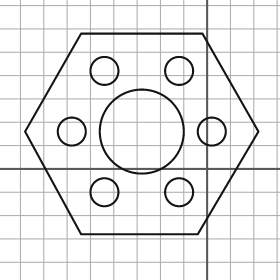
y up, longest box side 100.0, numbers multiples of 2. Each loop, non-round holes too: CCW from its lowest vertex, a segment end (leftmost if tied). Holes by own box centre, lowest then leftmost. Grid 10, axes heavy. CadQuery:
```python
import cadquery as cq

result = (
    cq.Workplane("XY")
    .moveTo(-54.0, -28.0)
    .lineTo(-4.0, -28.0)
    .lineTo(22.0, 16.0)
    .lineTo(-2.0, 58.0)
    .lineTo(-54.0, 58.0)
    .lineTo(-78.0, 16.0)
    .close()
    .moveTo(-44.0, -10.0)
    .circle(6.0)
    .moveTo(-12.0, -10.0)
    .circle(6.0)
    .moveTo(-58.0, 16.0)
    .circle(6.0)
    .moveTo(-28.0, 16.0)
    .circle(18.0)
    .moveTo(2.0, 16.0)
    .circle(6.0)
    .moveTo(-44.0, 42.0)
    .circle(6.0)
    .moveTo(-12.0, 42.0)
    .circle(6.0)
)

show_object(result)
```